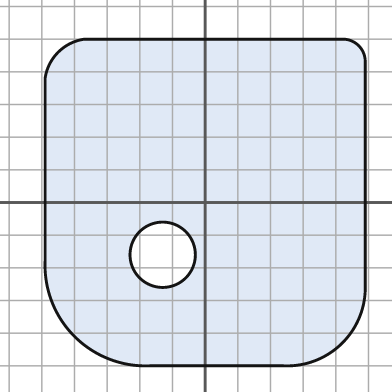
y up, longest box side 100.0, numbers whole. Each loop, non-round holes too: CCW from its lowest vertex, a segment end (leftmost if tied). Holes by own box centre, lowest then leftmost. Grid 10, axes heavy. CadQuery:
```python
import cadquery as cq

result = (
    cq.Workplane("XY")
    .moveTo(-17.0, -50.0)
    .lineTo(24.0, -50.0)
    .threePointArc((42.0, -43.0), (49.0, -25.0))
    .lineTo(49.0, 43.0)
    .threePointArc((47.0, 48.0), (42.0, 50.0))
    .lineTo(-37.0, 50.0)
    .threePointArc((-45.0, 46.0), (-49.0, 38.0))
    .lineTo(-49.0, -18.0)
    .threePointArc((-40.0, -41.0), (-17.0, -50.0))
    .close()
    .moveTo(-13.0, -16.0)
    .circle(10.0)
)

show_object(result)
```